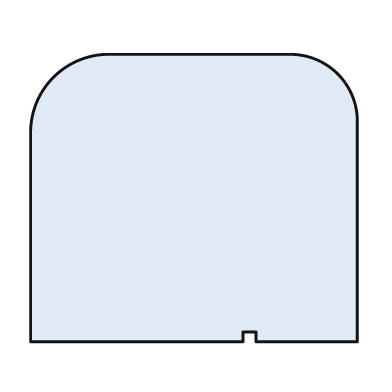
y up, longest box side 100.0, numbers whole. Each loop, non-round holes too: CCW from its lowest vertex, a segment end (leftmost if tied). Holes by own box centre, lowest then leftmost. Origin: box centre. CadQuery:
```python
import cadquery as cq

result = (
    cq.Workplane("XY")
    .moveTo(-50.0, -44.0)
    .lineTo(15.0, -44.0)
    .lineTo(15.0, -41.0)
    .lineTo(19.0, -41.0)
    .lineTo(19.0, -44.0)
    .lineTo(50.0, -44.0)
    .lineTo(50.0, 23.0)
    .threePointArc((44.0, 38.0), (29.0, 44.0))
    .lineTo(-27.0, 44.0)
    .threePointArc((-43.0, 37.0), (-50.0, 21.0))
    .close()
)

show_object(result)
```